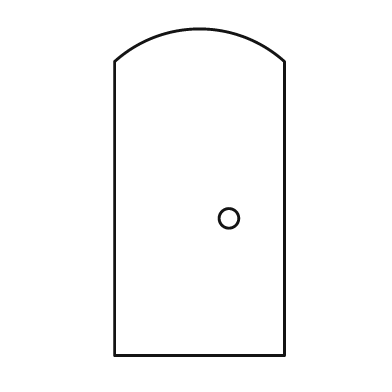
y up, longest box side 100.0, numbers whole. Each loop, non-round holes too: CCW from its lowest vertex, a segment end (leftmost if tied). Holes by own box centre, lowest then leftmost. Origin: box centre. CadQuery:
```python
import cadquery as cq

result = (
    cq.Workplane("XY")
    .moveTo(-26.0, -50.0)
    .lineTo(26.0, -50.0)
    .lineTo(26.0, 40.0)
    .threePointArc((0.0, 50.0), (-26.0, 40.0))
    .close()
    .moveTo(9.0, -8.0)
    .circle(3.0)
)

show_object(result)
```